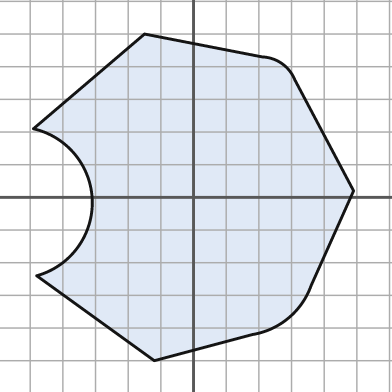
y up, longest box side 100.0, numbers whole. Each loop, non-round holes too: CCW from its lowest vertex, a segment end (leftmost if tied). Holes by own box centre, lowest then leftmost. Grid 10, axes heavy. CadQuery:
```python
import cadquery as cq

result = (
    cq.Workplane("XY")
    .moveTo(-12.0, -50.0)
    .lineTo(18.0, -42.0)
    .threePointArc((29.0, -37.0), (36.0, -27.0))
    .lineTo(49.0, 2.0)
    .lineTo(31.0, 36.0)
    .threePointArc((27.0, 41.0), (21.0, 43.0))
    .lineTo(-15.0, 50.0)
    .lineTo(-49.0, 21.0)
    .threePointArc((-31.0, -1.0), (-48.0, -24.0))
    .close()
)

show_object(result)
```